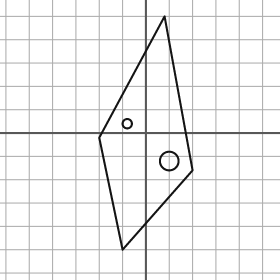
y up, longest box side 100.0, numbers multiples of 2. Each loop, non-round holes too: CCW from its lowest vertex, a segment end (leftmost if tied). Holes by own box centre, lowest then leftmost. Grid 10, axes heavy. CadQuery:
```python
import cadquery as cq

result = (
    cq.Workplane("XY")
    .moveTo(-10.0, -50.0)
    .lineTo(20.0, -16.0)
    .lineTo(8.0, 50.0)
    .lineTo(-20.0, -2.0)
    .close()
    .moveTo(10.0, -12.0)
    .circle(4.0)
    .moveTo(-8.0, 4.0)
    .circle(2.0)
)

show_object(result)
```